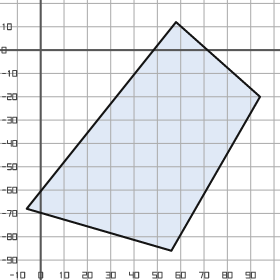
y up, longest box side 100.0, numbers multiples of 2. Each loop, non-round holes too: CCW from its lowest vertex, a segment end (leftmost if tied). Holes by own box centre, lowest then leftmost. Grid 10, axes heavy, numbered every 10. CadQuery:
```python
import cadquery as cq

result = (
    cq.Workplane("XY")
    .moveTo(56.0, -86.0)
    .lineTo(94.0, -20.0)
    .lineTo(58.0, 12.0)
    .lineTo(-6.0, -68.0)
    .close()
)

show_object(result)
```